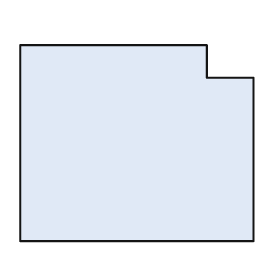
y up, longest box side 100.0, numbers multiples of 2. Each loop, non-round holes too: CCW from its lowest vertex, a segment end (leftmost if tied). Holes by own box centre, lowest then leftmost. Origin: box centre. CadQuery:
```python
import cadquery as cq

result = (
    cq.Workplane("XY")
    .moveTo(-50.0, -42.0)
    .lineTo(50.0, -42.0)
    .lineTo(50.0, 28.0)
    .lineTo(30.0, 28.0)
    .lineTo(30.0, 42.0)
    .lineTo(-50.0, 42.0)
    .close()
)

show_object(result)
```